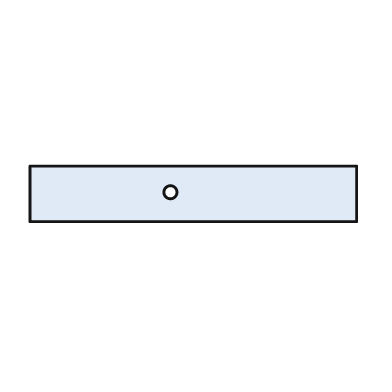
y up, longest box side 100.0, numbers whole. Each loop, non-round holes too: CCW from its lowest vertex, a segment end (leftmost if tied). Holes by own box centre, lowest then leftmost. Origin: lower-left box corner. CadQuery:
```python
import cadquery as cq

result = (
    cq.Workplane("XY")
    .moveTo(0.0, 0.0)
    .lineTo(100.0, 0.0)
    .lineTo(100.0, 17.0)
    .lineTo(0.0, 17.0)
    .close()
    .moveTo(43.0, 9.0)
    .circle(2.0)
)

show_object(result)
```